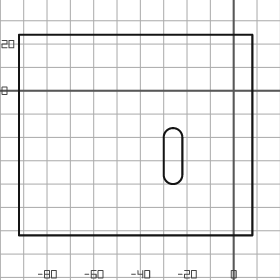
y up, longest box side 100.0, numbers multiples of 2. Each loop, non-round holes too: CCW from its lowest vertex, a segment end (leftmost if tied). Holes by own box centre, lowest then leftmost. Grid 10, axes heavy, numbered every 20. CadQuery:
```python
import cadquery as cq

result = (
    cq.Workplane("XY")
    .moveTo(-92.0, -62.0)
    .lineTo(8.0, -62.0)
    .lineTo(8.0, 24.0)
    .lineTo(-92.0, 24.0)
    .close()
    .moveTo(-30.0, -36.0)
    .threePointArc((-26.0, -40.0), (-22.0, -36.0))
    .lineTo(-22.0, -20.0)
    .threePointArc((-26.0, -16.0), (-30.0, -20.0))
    .close()
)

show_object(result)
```